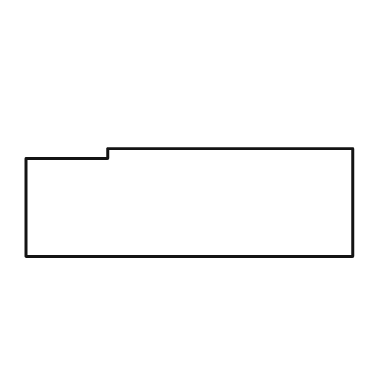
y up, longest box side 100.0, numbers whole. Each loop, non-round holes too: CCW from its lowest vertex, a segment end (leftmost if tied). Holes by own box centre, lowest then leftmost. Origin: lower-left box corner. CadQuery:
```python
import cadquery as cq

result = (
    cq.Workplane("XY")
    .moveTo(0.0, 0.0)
    .lineTo(100.0, 0.0)
    .lineTo(100.0, 33.0)
    .lineTo(25.0, 33.0)
    .lineTo(25.0, 30.0)
    .lineTo(0.0, 30.0)
    .close()
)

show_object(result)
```